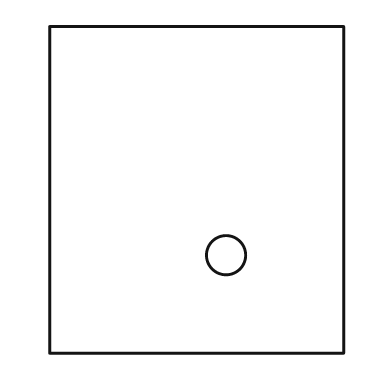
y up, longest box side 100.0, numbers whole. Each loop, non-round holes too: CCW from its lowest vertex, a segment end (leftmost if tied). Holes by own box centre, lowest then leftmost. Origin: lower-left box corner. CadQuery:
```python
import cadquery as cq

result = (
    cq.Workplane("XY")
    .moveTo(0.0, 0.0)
    .lineTo(90.0, 0.0)
    .lineTo(90.0, 100.0)
    .lineTo(0.0, 100.0)
    .close()
    .moveTo(54.0, 30.0)
    .circle(6.0)
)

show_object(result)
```